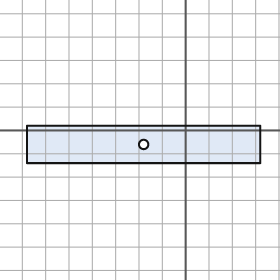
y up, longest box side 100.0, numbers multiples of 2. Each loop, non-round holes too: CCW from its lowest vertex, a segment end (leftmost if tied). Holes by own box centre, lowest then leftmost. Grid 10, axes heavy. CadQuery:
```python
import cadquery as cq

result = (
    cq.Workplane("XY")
    .moveTo(-68.0, -14.0)
    .lineTo(32.0, -14.0)
    .lineTo(32.0, 2.0)
    .lineTo(-68.0, 2.0)
    .close()
    .moveTo(-18.0, -6.0)
    .circle(2.0)
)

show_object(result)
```